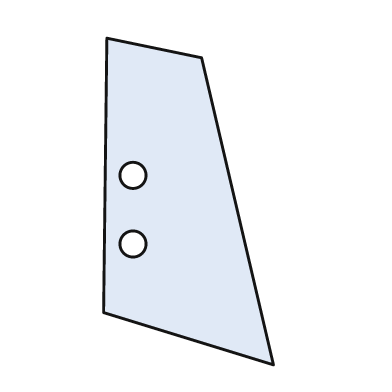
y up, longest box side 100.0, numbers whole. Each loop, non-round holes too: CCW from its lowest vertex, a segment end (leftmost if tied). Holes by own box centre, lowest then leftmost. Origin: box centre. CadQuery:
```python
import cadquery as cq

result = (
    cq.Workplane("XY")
    .moveTo(26.0, -50.0)
    .lineTo(4.0, 44.0)
    .lineTo(-25.0, 50.0)
    .lineTo(-26.0, -34.0)
    .close()
    .moveTo(-17.0, -13.0)
    .circle(4.0)
    .moveTo(-17.0, 8.0)
    .circle(4.0)
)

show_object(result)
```